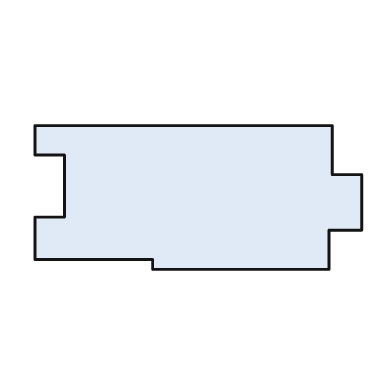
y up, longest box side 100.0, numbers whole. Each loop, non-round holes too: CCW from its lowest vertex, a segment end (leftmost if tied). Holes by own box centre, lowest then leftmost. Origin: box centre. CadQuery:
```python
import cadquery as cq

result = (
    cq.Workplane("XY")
    .moveTo(-14.0, -22.0)
    .lineTo(40.0, -22.0)
    .lineTo(40.0, -10.0)
    .lineTo(50.0, -10.0)
    .lineTo(50.0, 7.0)
    .lineTo(41.0, 7.0)
    .lineTo(41.0, 22.0)
    .lineTo(-50.0, 22.0)
    .lineTo(-50.0, 13.0)
    .lineTo(-41.0, 13.0)
    .lineTo(-41.0, -6.0)
    .lineTo(-50.0, -6.0)
    .lineTo(-50.0, -19.0)
    .lineTo(-14.0, -19.0)
    .close()
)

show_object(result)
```